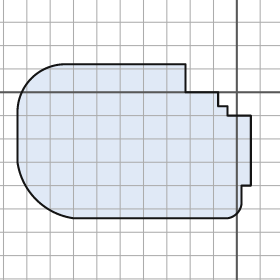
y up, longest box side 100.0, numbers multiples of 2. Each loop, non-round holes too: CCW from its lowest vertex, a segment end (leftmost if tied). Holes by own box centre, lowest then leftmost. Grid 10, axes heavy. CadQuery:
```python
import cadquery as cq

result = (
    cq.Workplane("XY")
    .moveTo(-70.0, -54.0)
    .lineTo(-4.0, -54.0)
    .threePointArc((0.0, -52.0), (2.0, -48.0))
    .lineTo(2.0, -40.0)
    .lineTo(6.0, -40.0)
    .lineTo(6.0, -10.0)
    .lineTo(-4.0, -10.0)
    .lineTo(-4.0, -6.0)
    .lineTo(-8.0, -6.0)
    .lineTo(-8.0, 0.0)
    .lineTo(-22.0, 0.0)
    .lineTo(-22.0, 12.0)
    .lineTo(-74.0, 12.0)
    .threePointArc((-88.0, 6.0), (-94.0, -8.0))
    .lineTo(-94.0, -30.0)
    .threePointArc((-86.0, -46.0), (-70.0, -54.0))
    .close()
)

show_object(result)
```